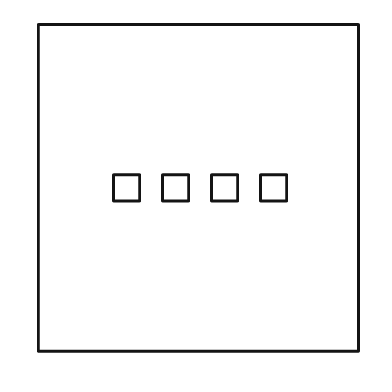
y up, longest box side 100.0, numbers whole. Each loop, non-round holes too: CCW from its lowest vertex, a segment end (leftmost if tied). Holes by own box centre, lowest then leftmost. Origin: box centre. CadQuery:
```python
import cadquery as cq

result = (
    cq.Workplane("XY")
    .moveTo(-49.0, -50.0)
    .lineTo(49.0, -50.0)
    .lineTo(49.0, 50.0)
    .lineTo(-49.0, 50.0)
    .close()
    .moveTo(-26.0, -4.0)
    .lineTo(-18.0, -4.0)
    .lineTo(-18.0, 4.0)
    .lineTo(-26.0, 4.0)
    .close()
    .moveTo(-11.0, -4.0)
    .lineTo(-3.0, -4.0)
    .lineTo(-3.0, 4.0)
    .lineTo(-11.0, 4.0)
    .close()
    .moveTo(4.0, -4.0)
    .lineTo(12.0, -4.0)
    .lineTo(12.0, 4.0)
    .lineTo(4.0, 4.0)
    .close()
    .moveTo(19.0, -4.0)
    .lineTo(27.0, -4.0)
    .lineTo(27.0, 4.0)
    .lineTo(19.0, 4.0)
    .close()
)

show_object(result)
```